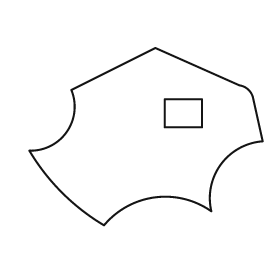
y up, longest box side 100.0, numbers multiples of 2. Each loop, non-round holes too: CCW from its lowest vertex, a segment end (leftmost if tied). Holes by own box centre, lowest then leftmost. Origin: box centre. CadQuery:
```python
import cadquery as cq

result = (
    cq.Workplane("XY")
    .moveTo(-18.0, -38.0)
    .threePointArc((4.0, -26.0), (28.0, -32.0))
    .threePointArc((32.0, -12.0), (50.0, -2.0))
    .lineTo(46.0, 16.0)
    .threePointArc((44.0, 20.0), (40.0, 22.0))
    .lineTo(4.0, 38.0)
    .lineTo(-32.0, 20.0)
    .threePointArc((-34.0, 2.0), (-50.0, -6.0))
    .threePointArc((-36.0, -24.0), (-18.0, -38.0))
    .close()
    .moveTo(8.0, 4.0)
    .lineTo(24.0, 4.0)
    .lineTo(24.0, 16.0)
    .lineTo(8.0, 16.0)
    .close()
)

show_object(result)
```